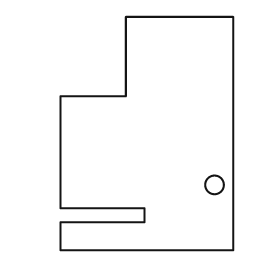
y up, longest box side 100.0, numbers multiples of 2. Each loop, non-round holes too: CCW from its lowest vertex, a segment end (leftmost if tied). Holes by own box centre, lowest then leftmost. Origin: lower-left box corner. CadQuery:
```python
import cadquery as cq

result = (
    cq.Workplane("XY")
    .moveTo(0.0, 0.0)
    .lineTo(74.0, 0.0)
    .lineTo(74.0, 100.0)
    .lineTo(28.0, 100.0)
    .lineTo(28.0, 66.0)
    .lineTo(0.0, 66.0)
    .lineTo(0.0, 18.0)
    .lineTo(36.0, 18.0)
    .lineTo(36.0, 12.0)
    .lineTo(0.0, 12.0)
    .close()
    .moveTo(66.0, 28.0)
    .circle(4.0)
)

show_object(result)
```